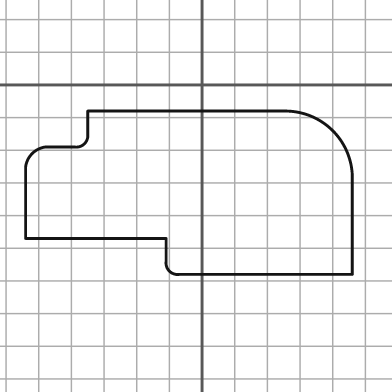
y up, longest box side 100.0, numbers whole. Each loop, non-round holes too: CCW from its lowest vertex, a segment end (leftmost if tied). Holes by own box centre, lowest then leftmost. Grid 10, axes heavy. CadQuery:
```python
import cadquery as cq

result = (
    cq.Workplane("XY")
    .moveTo(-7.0, -58.0)
    .lineTo(46.0, -58.0)
    .lineTo(46.0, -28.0)
    .threePointArc((40.0, -14.0), (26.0, -8.0))
    .lineTo(-35.0, -8.0)
    .lineTo(-35.0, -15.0)
    .threePointArc((-36.0, -18.0), (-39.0, -19.0))
    .lineTo(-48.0, -19.0)
    .threePointArc((-52.0, -21.0), (-54.0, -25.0))
    .lineTo(-54.0, -47.0)
    .lineTo(-11.0, -47.0)
    .lineTo(-11.0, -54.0)
    .threePointArc((-10.0, -57.0), (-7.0, -58.0))
    .close()
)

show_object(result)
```